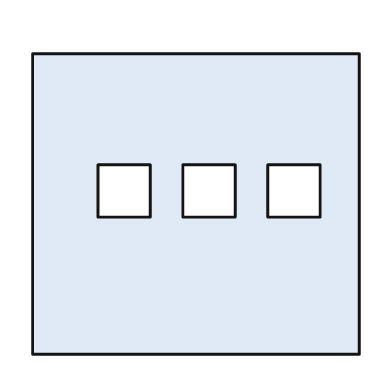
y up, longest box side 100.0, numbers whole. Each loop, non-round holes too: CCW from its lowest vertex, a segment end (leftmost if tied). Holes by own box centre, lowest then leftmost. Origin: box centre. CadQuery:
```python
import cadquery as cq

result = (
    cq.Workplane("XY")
    .moveTo(-50.0, -46.0)
    .lineTo(50.0, -46.0)
    .lineTo(50.0, 46.0)
    .lineTo(-50.0, 46.0)
    .close()
    .moveTo(-30.0, -4.0)
    .lineTo(-14.0, -4.0)
    .lineTo(-14.0, 12.0)
    .lineTo(-30.0, 12.0)
    .close()
    .moveTo(-4.0, -4.0)
    .lineTo(12.0, -4.0)
    .lineTo(12.0, 12.0)
    .lineTo(-4.0, 12.0)
    .close()
    .moveTo(22.0, -4.0)
    .lineTo(38.0, -4.0)
    .lineTo(38.0, 12.0)
    .lineTo(22.0, 12.0)
    .close()
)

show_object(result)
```